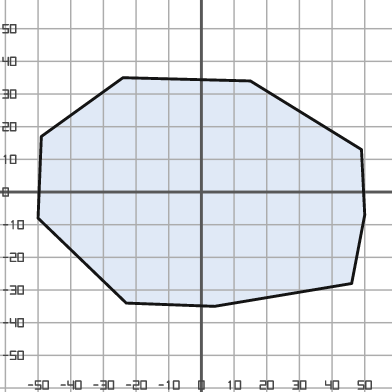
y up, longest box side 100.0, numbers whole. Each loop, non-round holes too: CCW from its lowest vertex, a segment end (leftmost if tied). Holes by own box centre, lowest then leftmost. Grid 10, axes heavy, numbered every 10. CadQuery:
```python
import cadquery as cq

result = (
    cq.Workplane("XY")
    .moveTo(4.0, -35.0)
    .lineTo(46.0, -28.0)
    .lineTo(50.0, -7.0)
    .lineTo(49.0, 13.0)
    .lineTo(15.0, 34.0)
    .lineTo(-24.0, 35.0)
    .lineTo(-49.0, 17.0)
    .lineTo(-50.0, -8.0)
    .lineTo(-23.0, -34.0)
    .close()
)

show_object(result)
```